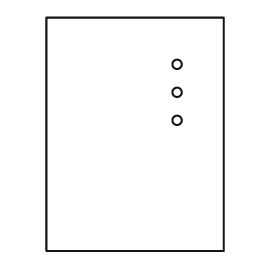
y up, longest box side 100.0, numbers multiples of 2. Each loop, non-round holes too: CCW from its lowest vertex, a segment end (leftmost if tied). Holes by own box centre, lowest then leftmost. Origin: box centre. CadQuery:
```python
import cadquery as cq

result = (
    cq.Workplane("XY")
    .moveTo(-38.0, -50.0)
    .lineTo(38.0, -50.0)
    .lineTo(38.0, 50.0)
    .lineTo(-38.0, 50.0)
    .close()
    .moveTo(18.0, 6.0)
    .circle(2.0)
    .moveTo(18.0, 18.0)
    .circle(2.0)
    .moveTo(18.0, 30.0)
    .circle(2.0)
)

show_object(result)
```